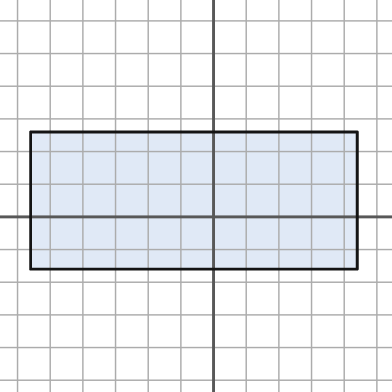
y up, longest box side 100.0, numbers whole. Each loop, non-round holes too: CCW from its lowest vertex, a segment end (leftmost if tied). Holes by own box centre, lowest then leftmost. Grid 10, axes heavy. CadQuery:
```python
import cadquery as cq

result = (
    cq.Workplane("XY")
    .moveTo(-56.0, -16.0)
    .lineTo(44.0, -16.0)
    .lineTo(44.0, 26.0)
    .lineTo(-56.0, 26.0)
    .close()
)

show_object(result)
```